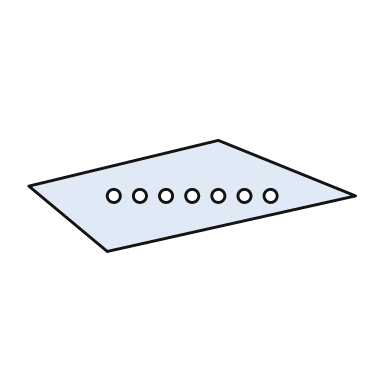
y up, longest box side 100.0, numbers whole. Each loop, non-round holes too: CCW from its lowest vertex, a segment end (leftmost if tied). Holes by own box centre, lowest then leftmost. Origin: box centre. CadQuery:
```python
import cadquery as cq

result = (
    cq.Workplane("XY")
    .moveTo(-26.0, -17.0)
    .lineTo(50.0, 0.0)
    .lineTo(8.0, 17.0)
    .lineTo(-50.0, 3.0)
    .close()
    .moveTo(-24.0, 0.0)
    .circle(2.0)
    .moveTo(-16.0, 0.0)
    .circle(2.0)
    .moveTo(-8.0, 0.0)
    .circle(2.0)
    .moveTo(0.0, 0.0)
    .circle(2.0)
    .moveTo(8.0, 0.0)
    .circle(2.0)
    .moveTo(16.0, 0.0)
    .circle(2.0)
    .moveTo(24.0, 0.0)
    .circle(2.0)
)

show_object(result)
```